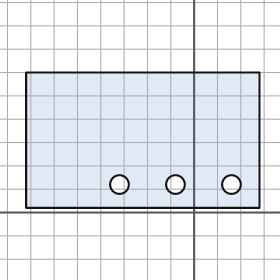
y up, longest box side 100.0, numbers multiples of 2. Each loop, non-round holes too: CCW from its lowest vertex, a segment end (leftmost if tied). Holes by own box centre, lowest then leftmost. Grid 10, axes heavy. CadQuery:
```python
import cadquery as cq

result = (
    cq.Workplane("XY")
    .moveTo(-72.0, 2.0)
    .lineTo(28.0, 2.0)
    .lineTo(28.0, 60.0)
    .lineTo(-72.0, 60.0)
    .close()
    .moveTo(-32.0, 12.0)
    .circle(4.0)
    .moveTo(-8.0, 12.0)
    .circle(4.0)
    .moveTo(16.0, 12.0)
    .circle(4.0)
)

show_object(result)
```